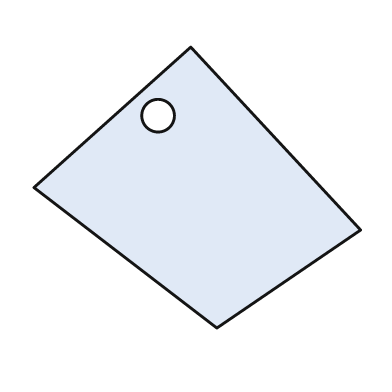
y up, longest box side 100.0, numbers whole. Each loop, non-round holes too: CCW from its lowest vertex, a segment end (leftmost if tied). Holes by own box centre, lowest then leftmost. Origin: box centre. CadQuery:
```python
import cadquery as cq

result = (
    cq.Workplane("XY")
    .moveTo(6.0, -43.0)
    .lineTo(50.0, -13.0)
    .lineTo(-2.0, 43.0)
    .lineTo(-50.0, 0.0)
    .close()
    .moveTo(-12.0, 22.0)
    .circle(5.0)
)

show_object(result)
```